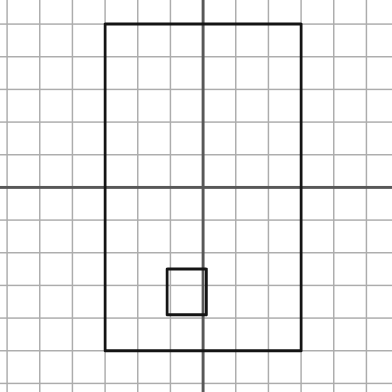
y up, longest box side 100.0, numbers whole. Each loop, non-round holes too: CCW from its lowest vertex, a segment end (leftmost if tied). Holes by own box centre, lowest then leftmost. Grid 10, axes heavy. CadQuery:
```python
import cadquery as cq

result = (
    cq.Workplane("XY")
    .moveTo(-30.0, -50.0)
    .lineTo(30.0, -50.0)
    .lineTo(30.0, 50.0)
    .lineTo(-30.0, 50.0)
    .close()
    .moveTo(-11.0, -39.0)
    .lineTo(1.0, -39.0)
    .lineTo(1.0, -25.0)
    .lineTo(-11.0, -25.0)
    .close()
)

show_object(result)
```